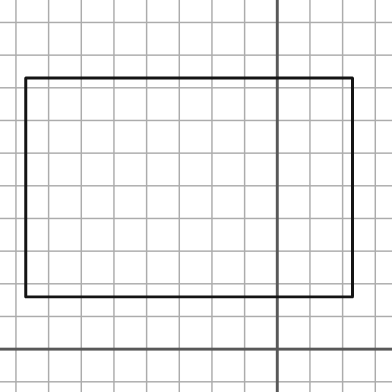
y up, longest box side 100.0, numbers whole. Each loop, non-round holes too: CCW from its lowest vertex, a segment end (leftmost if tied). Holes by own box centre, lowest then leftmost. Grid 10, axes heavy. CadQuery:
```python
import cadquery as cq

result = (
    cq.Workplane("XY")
    .moveTo(-77.0, 16.0)
    .lineTo(23.0, 16.0)
    .lineTo(23.0, 83.0)
    .lineTo(-77.0, 83.0)
    .close()
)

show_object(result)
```